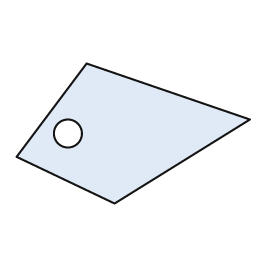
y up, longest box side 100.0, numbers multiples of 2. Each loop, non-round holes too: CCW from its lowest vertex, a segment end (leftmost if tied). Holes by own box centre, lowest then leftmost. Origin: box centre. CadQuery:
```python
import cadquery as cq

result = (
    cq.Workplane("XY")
    .moveTo(-8.0, -30.0)
    .lineTo(50.0, 6.0)
    .lineTo(-20.0, 30.0)
    .lineTo(-50.0, -10.0)
    .close()
    .moveTo(-28.0, 0.0)
    .circle(6.0)
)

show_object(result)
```